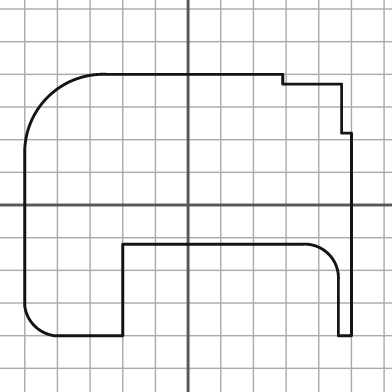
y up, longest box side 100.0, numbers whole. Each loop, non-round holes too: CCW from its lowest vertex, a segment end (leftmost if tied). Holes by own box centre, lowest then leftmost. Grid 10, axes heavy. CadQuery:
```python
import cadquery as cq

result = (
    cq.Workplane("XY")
    .moveTo(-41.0, -40.0)
    .lineTo(-20.0, -40.0)
    .lineTo(-20.0, -12.0)
    .lineTo(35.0, -12.0)
    .threePointArc((43.0, -15.0), (46.0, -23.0))
    .lineTo(46.0, -40.0)
    .lineTo(50.0, -40.0)
    .lineTo(50.0, 22.0)
    .lineTo(47.0, 22.0)
    .lineTo(47.0, 37.0)
    .lineTo(29.0, 37.0)
    .lineTo(29.0, 40.0)
    .lineTo(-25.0, 40.0)
    .threePointArc((-43.0, 33.0), (-50.0, 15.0))
    .lineTo(-50.0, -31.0)
    .threePointArc((-47.0, -37.0), (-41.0, -40.0))
    .close()
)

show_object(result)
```